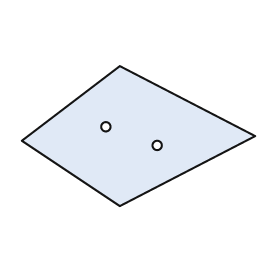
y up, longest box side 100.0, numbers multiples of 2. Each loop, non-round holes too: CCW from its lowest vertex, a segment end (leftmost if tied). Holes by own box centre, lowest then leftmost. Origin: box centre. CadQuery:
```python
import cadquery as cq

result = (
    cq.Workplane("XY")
    .moveTo(-8.0, -30.0)
    .lineTo(50.0, 0.0)
    .lineTo(-8.0, 30.0)
    .lineTo(-50.0, -2.0)
    .close()
    .moveTo(8.0, -4.0)
    .circle(2.0)
    .moveTo(-14.0, 4.0)
    .circle(2.0)
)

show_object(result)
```